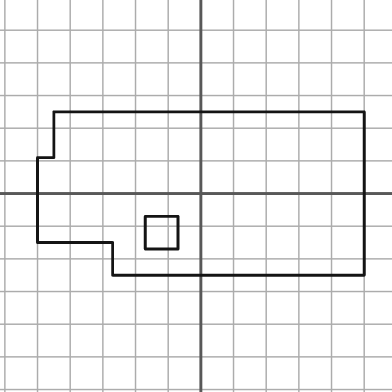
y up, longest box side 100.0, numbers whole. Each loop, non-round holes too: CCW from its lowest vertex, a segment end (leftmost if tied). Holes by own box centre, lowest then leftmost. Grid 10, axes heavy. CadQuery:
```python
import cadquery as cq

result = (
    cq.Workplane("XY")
    .moveTo(-27.0, -25.0)
    .lineTo(50.0, -25.0)
    .lineTo(50.0, 25.0)
    .lineTo(-45.0, 25.0)
    .lineTo(-45.0, 11.0)
    .lineTo(-50.0, 11.0)
    .lineTo(-50.0, -15.0)
    .lineTo(-27.0, -15.0)
    .close()
    .moveTo(-17.0, -17.0)
    .lineTo(-7.0, -17.0)
    .lineTo(-7.0, -7.0)
    .lineTo(-17.0, -7.0)
    .close()
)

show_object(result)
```